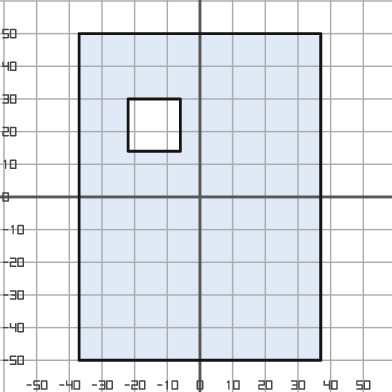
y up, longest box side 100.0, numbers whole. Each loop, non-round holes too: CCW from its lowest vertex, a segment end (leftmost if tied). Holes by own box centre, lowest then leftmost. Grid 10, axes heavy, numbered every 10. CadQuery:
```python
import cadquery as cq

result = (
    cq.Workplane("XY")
    .moveTo(-37.0, -50.0)
    .lineTo(37.0, -50.0)
    .lineTo(37.0, 50.0)
    .lineTo(-37.0, 50.0)
    .close()
    .moveTo(-22.0, 14.0)
    .lineTo(-6.0, 14.0)
    .lineTo(-6.0, 30.0)
    .lineTo(-22.0, 30.0)
    .close()
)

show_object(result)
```